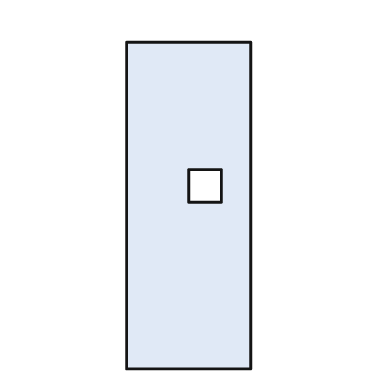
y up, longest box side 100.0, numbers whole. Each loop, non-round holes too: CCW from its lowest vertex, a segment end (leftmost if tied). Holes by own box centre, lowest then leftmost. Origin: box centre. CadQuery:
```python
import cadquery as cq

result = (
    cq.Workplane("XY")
    .moveTo(-19.0, -50.0)
    .lineTo(19.0, -50.0)
    .lineTo(19.0, 50.0)
    .lineTo(-19.0, 50.0)
    .close()
    .moveTo(0.0, 1.0)
    .lineTo(10.0, 1.0)
    .lineTo(10.0, 11.0)
    .lineTo(0.0, 11.0)
    .close()
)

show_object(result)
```